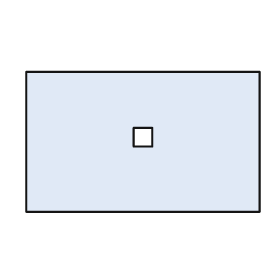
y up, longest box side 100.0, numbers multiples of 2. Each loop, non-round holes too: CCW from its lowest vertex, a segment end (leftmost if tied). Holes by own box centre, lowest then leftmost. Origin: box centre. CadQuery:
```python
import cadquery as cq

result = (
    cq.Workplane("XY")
    .moveTo(-50.0, -30.0)
    .lineTo(50.0, -30.0)
    .lineTo(50.0, 30.0)
    .lineTo(-50.0, 30.0)
    .close()
    .moveTo(-4.0, -2.0)
    .lineTo(4.0, -2.0)
    .lineTo(4.0, 6.0)
    .lineTo(-4.0, 6.0)
    .close()
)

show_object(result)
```